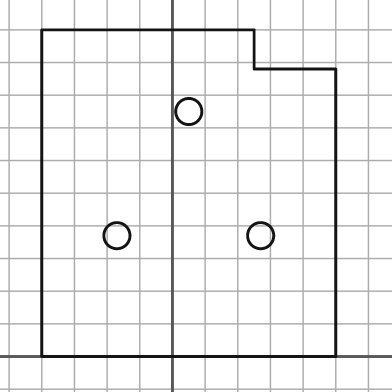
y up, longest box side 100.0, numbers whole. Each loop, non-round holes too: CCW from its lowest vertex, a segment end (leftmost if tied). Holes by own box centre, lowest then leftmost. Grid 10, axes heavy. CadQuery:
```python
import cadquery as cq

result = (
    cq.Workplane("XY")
    .moveTo(-40.0, 0.0)
    .lineTo(50.0, 0.0)
    .lineTo(50.0, 88.0)
    .lineTo(25.0, 88.0)
    .lineTo(25.0, 100.0)
    .lineTo(-40.0, 100.0)
    .close()
    .moveTo(-17.0, 37.0)
    .circle(4.0)
    .moveTo(27.0, 37.0)
    .circle(4.0)
    .moveTo(5.0, 75.0)
    .circle(4.0)
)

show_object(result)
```